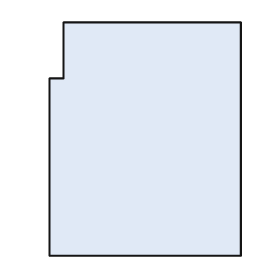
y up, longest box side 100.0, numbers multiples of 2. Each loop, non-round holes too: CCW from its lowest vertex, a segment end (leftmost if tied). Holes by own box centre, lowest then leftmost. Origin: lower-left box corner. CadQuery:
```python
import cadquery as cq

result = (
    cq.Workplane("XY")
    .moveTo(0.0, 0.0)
    .lineTo(82.0, 0.0)
    .lineTo(82.0, 100.0)
    .lineTo(6.0, 100.0)
    .lineTo(6.0, 76.0)
    .lineTo(0.0, 76.0)
    .close()
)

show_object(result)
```